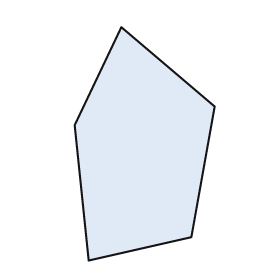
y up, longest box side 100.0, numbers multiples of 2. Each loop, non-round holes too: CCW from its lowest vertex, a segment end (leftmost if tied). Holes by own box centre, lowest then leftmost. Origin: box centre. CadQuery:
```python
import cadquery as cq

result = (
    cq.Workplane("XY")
    .moveTo(-24.0, -50.0)
    .lineTo(20.0, -40.0)
    .lineTo(30.0, 16.0)
    .lineTo(-10.0, 50.0)
    .lineTo(-30.0, 8.0)
    .close()
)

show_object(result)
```